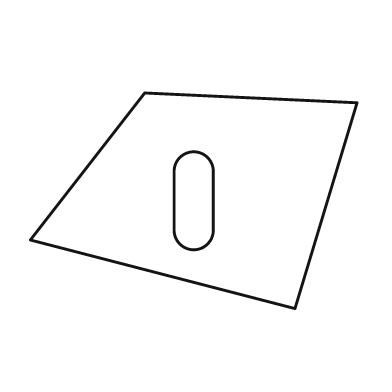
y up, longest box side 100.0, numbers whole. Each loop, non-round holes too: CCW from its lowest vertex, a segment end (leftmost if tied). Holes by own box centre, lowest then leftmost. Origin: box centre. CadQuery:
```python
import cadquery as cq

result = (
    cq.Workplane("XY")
    .moveTo(31.0, -33.0)
    .lineTo(50.0, 30.0)
    .lineTo(-15.0, 33.0)
    .lineTo(-50.0, -12.0)
    .close()
    .moveTo(-6.0, -9.0)
    .threePointArc((0.0, -15.0), (6.0, -9.0))
    .lineTo(6.0, 9.0)
    .threePointArc((0.0, 15.0), (-6.0, 9.0))
    .close()
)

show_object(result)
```